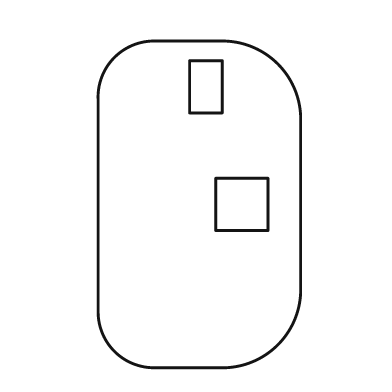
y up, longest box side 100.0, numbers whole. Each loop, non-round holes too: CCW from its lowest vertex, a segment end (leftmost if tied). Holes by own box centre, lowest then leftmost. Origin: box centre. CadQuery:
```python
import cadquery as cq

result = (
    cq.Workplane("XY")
    .moveTo(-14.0, -50.0)
    .lineTo(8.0, -50.0)
    .threePointArc((24.0, -43.0), (31.0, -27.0))
    .lineTo(31.0, 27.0)
    .threePointArc((24.0, 43.0), (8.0, 50.0))
    .lineTo(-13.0, 50.0)
    .threePointArc((-26.0, 45.0), (-31.0, 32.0))
    .lineTo(-31.0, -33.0)
    .threePointArc((-26.0, -45.0), (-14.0, -50.0))
    .close()
    .moveTo(5.0, -8.0)
    .lineTo(21.0, -8.0)
    .lineTo(21.0, 8.0)
    .lineTo(5.0, 8.0)
    .close()
    .moveTo(-3.0, 28.0)
    .lineTo(7.0, 28.0)
    .lineTo(7.0, 44.0)
    .lineTo(-3.0, 44.0)
    .close()
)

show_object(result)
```